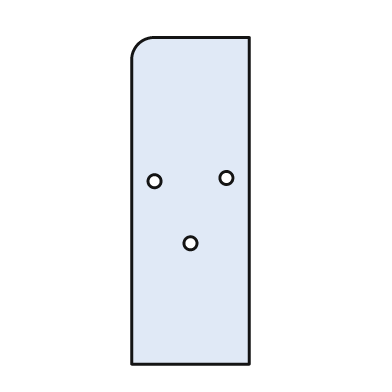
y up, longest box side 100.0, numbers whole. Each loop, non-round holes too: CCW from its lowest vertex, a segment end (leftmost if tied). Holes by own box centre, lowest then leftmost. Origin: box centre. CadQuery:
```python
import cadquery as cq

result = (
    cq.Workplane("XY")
    .moveTo(-18.0, -50.0)
    .lineTo(18.0, -50.0)
    .lineTo(18.0, 50.0)
    .lineTo(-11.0, 50.0)
    .threePointArc((-16.0, 48.0), (-18.0, 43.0))
    .close()
    .moveTo(0.0, -13.0)
    .circle(2.0)
    .moveTo(-11.0, 6.0)
    .circle(2.0)
    .moveTo(11.0, 7.0)
    .circle(2.0)
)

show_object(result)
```